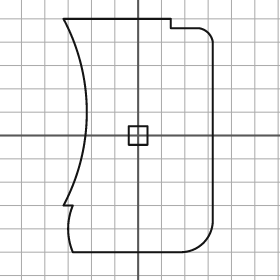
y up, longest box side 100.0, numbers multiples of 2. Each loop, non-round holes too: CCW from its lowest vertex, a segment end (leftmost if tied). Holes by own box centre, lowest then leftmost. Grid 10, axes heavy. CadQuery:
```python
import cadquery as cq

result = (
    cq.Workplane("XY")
    .moveTo(-28.0, -50.0)
    .lineTo(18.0, -50.0)
    .threePointArc((28.0, -46.0), (32.0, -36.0))
    .lineTo(32.0, 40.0)
    .threePointArc((30.0, 44.0), (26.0, 46.0))
    .lineTo(14.0, 46.0)
    .lineTo(14.0, 50.0)
    .lineTo(-32.0, 50.0)
    .threePointArc((-22.0, 10.0), (-32.0, -30.0))
    .lineTo(-28.0, -30.0)
    .threePointArc((-30.0, -40.0), (-28.0, -50.0))
    .close()
    .moveTo(-4.0, -4.0)
    .lineTo(4.0, -4.0)
    .lineTo(4.0, 4.0)
    .lineTo(-4.0, 4.0)
    .close()
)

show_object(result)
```